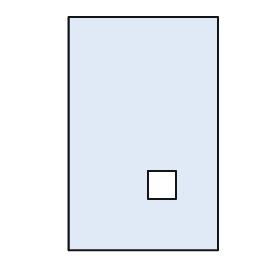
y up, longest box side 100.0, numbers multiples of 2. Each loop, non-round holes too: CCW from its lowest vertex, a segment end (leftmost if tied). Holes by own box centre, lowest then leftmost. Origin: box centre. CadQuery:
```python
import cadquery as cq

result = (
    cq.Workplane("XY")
    .moveTo(-32.0, -50.0)
    .lineTo(32.0, -50.0)
    .lineTo(32.0, 50.0)
    .lineTo(-32.0, 50.0)
    .close()
    .moveTo(2.0, -28.0)
    .lineTo(14.0, -28.0)
    .lineTo(14.0, -16.0)
    .lineTo(2.0, -16.0)
    .close()
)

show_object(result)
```